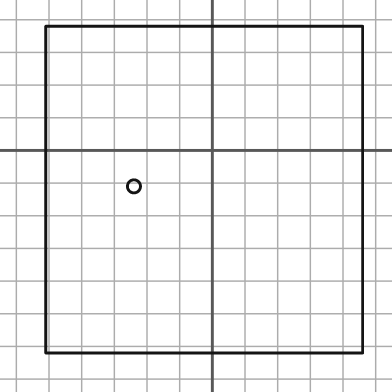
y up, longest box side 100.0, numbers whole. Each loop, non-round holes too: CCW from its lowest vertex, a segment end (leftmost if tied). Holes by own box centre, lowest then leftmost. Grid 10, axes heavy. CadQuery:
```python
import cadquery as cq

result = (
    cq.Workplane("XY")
    .moveTo(-51.0, -62.0)
    .lineTo(46.0, -62.0)
    .lineTo(46.0, 38.0)
    .lineTo(-51.0, 38.0)
    .close()
    .moveTo(-24.0, -11.0)
    .circle(2.0)
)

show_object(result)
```